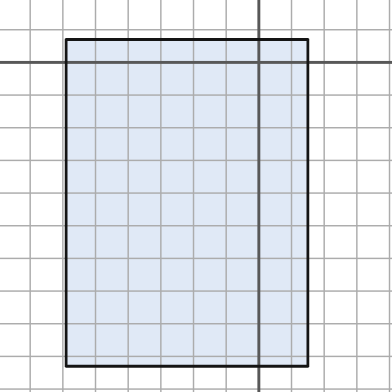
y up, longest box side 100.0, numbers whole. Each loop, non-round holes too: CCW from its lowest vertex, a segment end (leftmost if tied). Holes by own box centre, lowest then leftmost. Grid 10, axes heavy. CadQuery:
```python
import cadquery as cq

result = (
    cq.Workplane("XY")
    .moveTo(-59.0, -93.0)
    .lineTo(15.0, -93.0)
    .lineTo(15.0, 7.0)
    .lineTo(-59.0, 7.0)
    .close()
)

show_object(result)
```